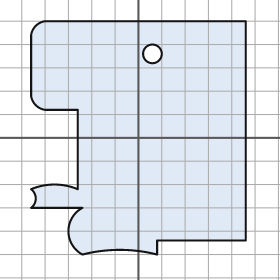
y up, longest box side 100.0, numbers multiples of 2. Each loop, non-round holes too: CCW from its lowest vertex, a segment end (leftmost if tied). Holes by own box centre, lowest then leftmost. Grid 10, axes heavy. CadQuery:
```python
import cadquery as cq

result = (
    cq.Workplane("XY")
    .moveTo(-24.0, -50.0)
    .threePointArc((-8.0, -48.0), (8.0, -50.0))
    .lineTo(8.0, -44.0)
    .lineTo(46.0, -44.0)
    .lineTo(46.0, 50.0)
    .lineTo(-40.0, 50.0)
    .threePointArc((-44.0, 48.0), (-46.0, 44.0))
    .lineTo(-46.0, 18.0)
    .threePointArc((-44.0, 14.0), (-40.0, 12.0))
    .lineTo(-26.0, 12.0)
    .lineTo(-26.0, -22.0)
    .threePointArc((-36.0, -20.0), (-46.0, -22.0))
    .threePointArc((-44.0, -26.0), (-46.0, -30.0))
    .lineTo(-24.0, -30.0)
    .threePointArc((-30.0, -40.0), (-24.0, -50.0))
    .close()
    .moveTo(6.0, 36.0)
    .circle(4.0)
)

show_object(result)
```